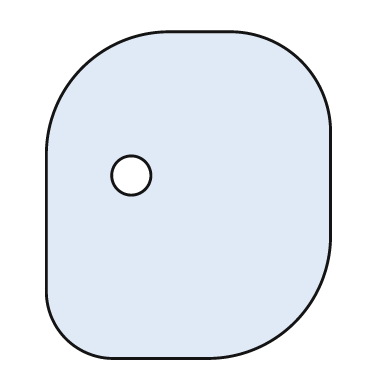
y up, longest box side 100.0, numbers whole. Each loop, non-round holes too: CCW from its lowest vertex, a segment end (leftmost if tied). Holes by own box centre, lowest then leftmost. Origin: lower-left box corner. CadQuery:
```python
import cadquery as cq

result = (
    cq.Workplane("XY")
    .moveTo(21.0, 0.0)
    .lineTo(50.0, 0.0)
    .threePointArc((76.0, 11.0), (87.0, 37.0))
    .lineTo(87.0, 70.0)
    .threePointArc((78.0, 91.0), (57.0, 100.0))
    .lineTo(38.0, 100.0)
    .threePointArc((11.0, 89.0), (0.0, 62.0))
    .lineTo(0.0, 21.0)
    .threePointArc((6.0, 6.0), (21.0, 0.0))
    .close()
    .moveTo(26.0, 56.0)
    .circle(6.0)
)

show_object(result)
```